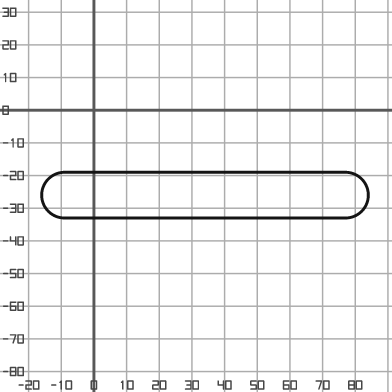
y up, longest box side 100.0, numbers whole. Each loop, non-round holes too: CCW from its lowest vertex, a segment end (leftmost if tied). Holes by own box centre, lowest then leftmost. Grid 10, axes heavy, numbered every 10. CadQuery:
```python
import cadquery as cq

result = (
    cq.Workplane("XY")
    .moveTo(-9.0, -33.0)
    .lineTo(77.0, -33.0)
    .threePointArc((84.0, -26.0), (77.0, -19.0))
    .lineTo(-9.0, -19.0)
    .threePointArc((-16.0, -26.0), (-9.0, -33.0))
    .close()
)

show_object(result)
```